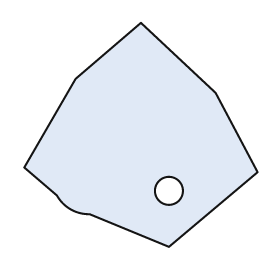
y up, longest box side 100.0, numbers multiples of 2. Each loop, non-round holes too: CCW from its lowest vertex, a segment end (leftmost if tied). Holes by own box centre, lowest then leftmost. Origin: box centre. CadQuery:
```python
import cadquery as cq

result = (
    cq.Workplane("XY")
    .moveTo(12.0, -48.0)
    .lineTo(50.0, -16.0)
    .lineTo(32.0, 18.0)
    .lineTo(0.0, 48.0)
    .lineTo(-28.0, 24.0)
    .lineTo(-50.0, -14.0)
    .lineTo(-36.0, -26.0)
    .threePointArc((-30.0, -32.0), (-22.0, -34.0))
    .close()
    .moveTo(12.0, -24.0)
    .circle(6.0)
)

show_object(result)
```